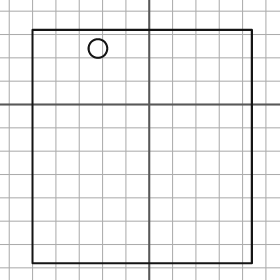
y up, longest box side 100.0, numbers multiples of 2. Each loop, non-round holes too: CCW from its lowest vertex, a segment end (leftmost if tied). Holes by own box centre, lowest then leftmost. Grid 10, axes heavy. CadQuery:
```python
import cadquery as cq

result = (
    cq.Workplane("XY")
    .moveTo(-50.0, -68.0)
    .lineTo(44.0, -68.0)
    .lineTo(44.0, 32.0)
    .lineTo(-50.0, 32.0)
    .close()
    .moveTo(-22.0, 24.0)
    .circle(4.0)
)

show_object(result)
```